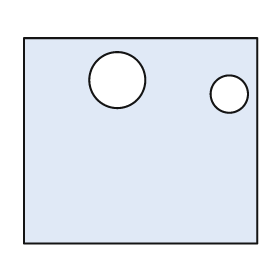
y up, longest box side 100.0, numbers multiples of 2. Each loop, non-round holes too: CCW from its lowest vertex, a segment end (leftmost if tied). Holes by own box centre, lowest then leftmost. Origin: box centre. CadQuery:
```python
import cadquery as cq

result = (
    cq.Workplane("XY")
    .moveTo(-50.0, -44.0)
    .lineTo(50.0, -44.0)
    .lineTo(50.0, 44.0)
    .lineTo(-50.0, 44.0)
    .close()
    .moveTo(38.0, 20.0)
    .circle(8.0)
    .moveTo(-10.0, 26.0)
    .circle(12.0)
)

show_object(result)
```